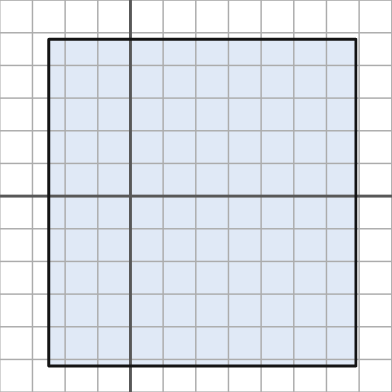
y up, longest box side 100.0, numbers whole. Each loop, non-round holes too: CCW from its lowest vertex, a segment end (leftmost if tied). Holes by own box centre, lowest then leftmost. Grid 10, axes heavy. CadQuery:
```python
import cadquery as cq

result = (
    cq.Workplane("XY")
    .moveTo(-25.0, -52.0)
    .lineTo(69.0, -52.0)
    .lineTo(69.0, 48.0)
    .lineTo(-25.0, 48.0)
    .close()
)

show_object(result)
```